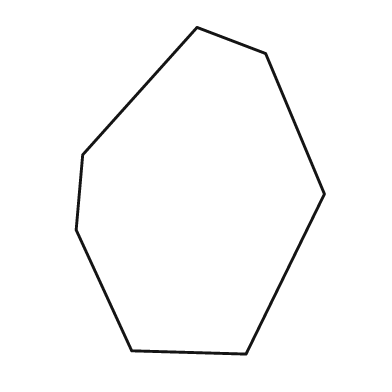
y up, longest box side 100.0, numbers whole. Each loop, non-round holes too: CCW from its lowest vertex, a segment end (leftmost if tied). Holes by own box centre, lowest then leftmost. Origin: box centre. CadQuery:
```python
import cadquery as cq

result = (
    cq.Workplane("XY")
    .moveTo(14.0, -50.0)
    .lineTo(38.0, -1.0)
    .lineTo(20.0, 42.0)
    .lineTo(-1.0, 50.0)
    .lineTo(-36.0, 11.0)
    .lineTo(-38.0, -12.0)
    .lineTo(-21.0, -49.0)
    .close()
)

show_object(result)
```